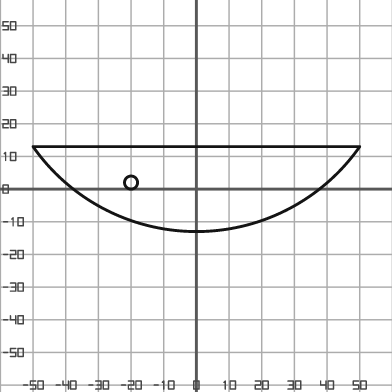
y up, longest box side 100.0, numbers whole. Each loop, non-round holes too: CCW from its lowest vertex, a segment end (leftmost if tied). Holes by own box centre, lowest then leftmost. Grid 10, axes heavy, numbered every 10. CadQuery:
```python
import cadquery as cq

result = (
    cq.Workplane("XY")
    .moveTo(-50.0, 13.0)
    .threePointArc((0.0, -13.0), (50.0, 13.0))
    .close()
    .moveTo(-20.0, 2.0)
    .circle(2.0)
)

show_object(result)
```